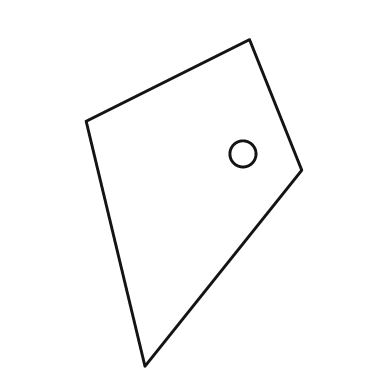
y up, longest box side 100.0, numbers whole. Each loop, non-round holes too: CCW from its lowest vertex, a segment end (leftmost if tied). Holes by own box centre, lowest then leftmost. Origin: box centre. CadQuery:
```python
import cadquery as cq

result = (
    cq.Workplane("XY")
    .moveTo(-15.0, -50.0)
    .lineTo(33.0, 10.0)
    .lineTo(17.0, 50.0)
    .lineTo(-33.0, 25.0)
    .close()
    .moveTo(15.0, 15.0)
    .circle(4.0)
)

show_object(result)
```